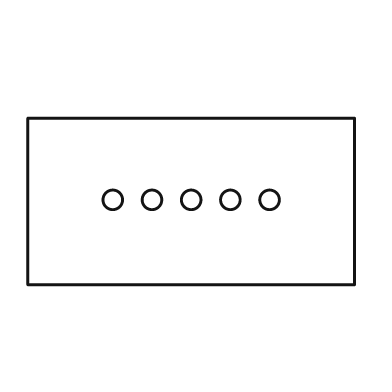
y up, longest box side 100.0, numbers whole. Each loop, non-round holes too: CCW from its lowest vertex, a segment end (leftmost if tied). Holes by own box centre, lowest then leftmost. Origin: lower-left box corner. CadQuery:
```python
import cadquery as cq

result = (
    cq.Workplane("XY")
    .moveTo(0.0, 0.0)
    .lineTo(100.0, 0.0)
    .lineTo(100.0, 51.0)
    .lineTo(0.0, 51.0)
    .close()
    .moveTo(26.0, 26.0)
    .circle(3.0)
    .moveTo(38.0, 26.0)
    .circle(3.0)
    .moveTo(50.0, 26.0)
    .circle(3.0)
    .moveTo(62.0, 26.0)
    .circle(3.0)
    .moveTo(74.0, 26.0)
    .circle(3.0)
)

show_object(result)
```